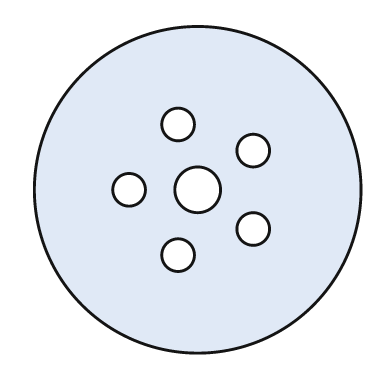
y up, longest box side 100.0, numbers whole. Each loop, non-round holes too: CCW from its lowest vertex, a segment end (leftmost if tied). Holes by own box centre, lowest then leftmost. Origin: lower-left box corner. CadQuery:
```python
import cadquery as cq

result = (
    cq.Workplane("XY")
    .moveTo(50.0, 50.0)
    .circle(50.0)
    .moveTo(44.0, 30.0)
    .circle(5.0)
    .moveTo(67.0, 38.0)
    .circle(5.0)
    .moveTo(29.0, 50.0)
    .circle(5.0)
    .moveTo(50.0, 50.0)
    .circle(7.0)
    .moveTo(67.0, 62.0)
    .circle(5.0)
    .moveTo(44.0, 70.0)
    .circle(5.0)
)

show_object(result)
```